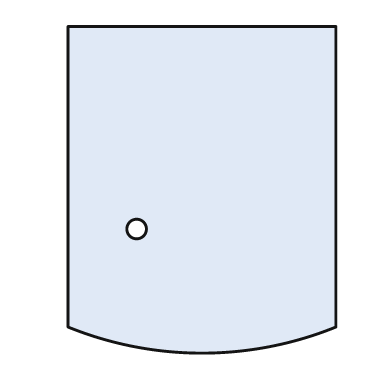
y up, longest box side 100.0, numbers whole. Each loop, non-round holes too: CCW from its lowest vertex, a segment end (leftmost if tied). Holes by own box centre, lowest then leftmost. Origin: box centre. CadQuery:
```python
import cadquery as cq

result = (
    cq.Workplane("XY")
    .moveTo(-41.0, -42.0)
    .threePointArc((0.0, -50.0), (41.0, -42.0))
    .lineTo(41.0, 50.0)
    .lineTo(-41.0, 50.0)
    .close()
    .moveTo(-20.0, -12.0)
    .circle(3.0)
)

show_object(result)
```